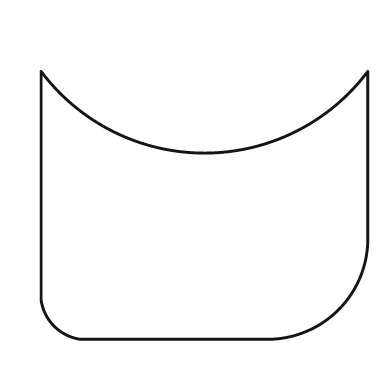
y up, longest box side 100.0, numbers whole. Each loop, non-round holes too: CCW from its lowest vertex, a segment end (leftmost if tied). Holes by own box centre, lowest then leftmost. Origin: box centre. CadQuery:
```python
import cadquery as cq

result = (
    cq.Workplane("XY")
    .moveTo(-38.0, -41.0)
    .lineTo(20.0, -41.0)
    .threePointArc((41.0, -32.0), (50.0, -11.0))
    .lineTo(50.0, 41.0)
    .threePointArc((0.0, 16.0), (-50.0, 41.0))
    .lineTo(-50.0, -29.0)
    .threePointArc((-46.0, -37.0), (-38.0, -41.0))
    .close()
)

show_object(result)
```